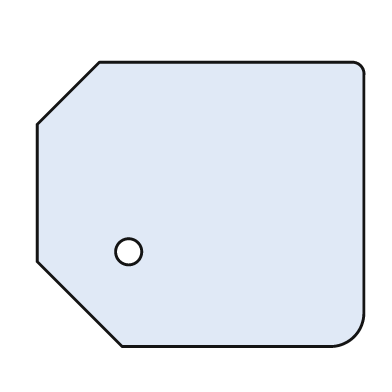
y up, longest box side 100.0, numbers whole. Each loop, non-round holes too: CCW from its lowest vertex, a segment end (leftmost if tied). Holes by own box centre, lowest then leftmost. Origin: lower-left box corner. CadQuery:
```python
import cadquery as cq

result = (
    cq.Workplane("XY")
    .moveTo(26.0, 0.0)
    .lineTo(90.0, 0.0)
    .threePointArc((97.0, 3.0), (100.0, 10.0))
    .lineTo(100.0, 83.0)
    .threePointArc((99.0, 86.0), (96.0, 87.0))
    .lineTo(19.0, 87.0)
    .lineTo(0.0, 68.0)
    .lineTo(0.0, 26.0)
    .close()
    .moveTo(28.0, 29.0)
    .circle(4.0)
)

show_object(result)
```